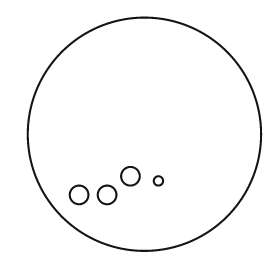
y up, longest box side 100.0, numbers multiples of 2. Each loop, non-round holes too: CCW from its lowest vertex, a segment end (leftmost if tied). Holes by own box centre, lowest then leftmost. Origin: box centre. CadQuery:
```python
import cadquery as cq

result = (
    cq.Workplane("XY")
    .moveTo(0.0, 0.0)
    .circle(50.0)
    .moveTo(-28.0, -26.0)
    .circle(4.0)
    .moveTo(-16.0, -26.0)
    .circle(4.0)
    .moveTo(6.0, -20.0)
    .circle(2.0)
    .moveTo(-6.0, -18.0)
    .circle(4.0)
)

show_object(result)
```